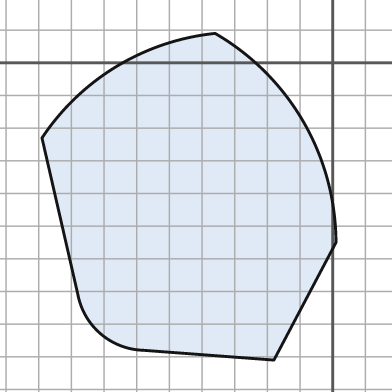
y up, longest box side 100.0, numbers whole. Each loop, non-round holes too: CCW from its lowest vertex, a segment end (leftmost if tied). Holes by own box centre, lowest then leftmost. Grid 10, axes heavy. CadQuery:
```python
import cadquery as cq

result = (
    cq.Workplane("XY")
    .moveTo(-18.0, -91.0)
    .lineTo(1.0, -55.0)
    .threePointArc((-9.0, -18.0), (-36.0, 9.0))
    .threePointArc((-66.0, -1.0), (-89.0, -23.0))
    .lineTo(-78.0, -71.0)
    .threePointArc((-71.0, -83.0), (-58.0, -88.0))
    .close()
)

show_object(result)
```